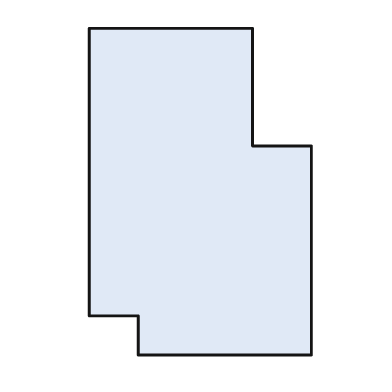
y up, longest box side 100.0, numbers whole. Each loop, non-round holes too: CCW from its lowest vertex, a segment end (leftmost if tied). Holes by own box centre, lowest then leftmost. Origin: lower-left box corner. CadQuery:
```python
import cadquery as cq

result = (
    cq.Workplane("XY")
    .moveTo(15.0, 0.0)
    .lineTo(68.0, 0.0)
    .lineTo(68.0, 64.0)
    .lineTo(50.0, 64.0)
    .lineTo(50.0, 100.0)
    .lineTo(0.0, 100.0)
    .lineTo(0.0, 12.0)
    .lineTo(15.0, 12.0)
    .close()
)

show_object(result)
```